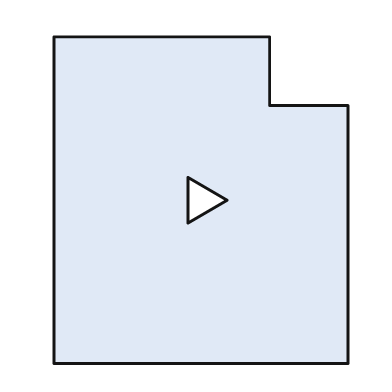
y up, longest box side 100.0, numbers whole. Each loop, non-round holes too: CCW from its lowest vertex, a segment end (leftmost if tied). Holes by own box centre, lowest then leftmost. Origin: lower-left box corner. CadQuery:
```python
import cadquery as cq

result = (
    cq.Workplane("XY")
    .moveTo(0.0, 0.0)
    .lineTo(90.0, 0.0)
    .lineTo(90.0, 79.0)
    .lineTo(66.0, 79.0)
    .lineTo(66.0, 100.0)
    .lineTo(0.0, 100.0)
    .close()
    .moveTo(41.0, 43.0)
    .lineTo(53.0, 50.0)
    .lineTo(41.0, 57.0)
    .close()
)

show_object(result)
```